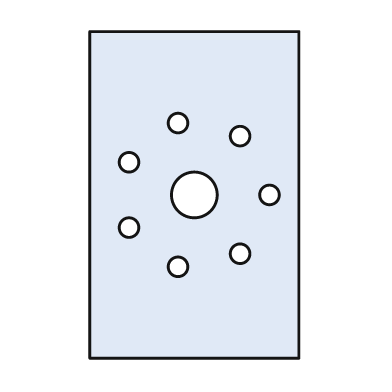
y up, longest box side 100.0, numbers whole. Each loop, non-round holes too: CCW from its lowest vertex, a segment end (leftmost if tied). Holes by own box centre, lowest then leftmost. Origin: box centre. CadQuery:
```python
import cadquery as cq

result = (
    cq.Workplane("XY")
    .moveTo(-32.0, -50.0)
    .lineTo(32.0, -50.0)
    .lineTo(32.0, 50.0)
    .lineTo(-32.0, 50.0)
    .close()
    .moveTo(-5.0, -22.0)
    .circle(3.0)
    .moveTo(14.0, -18.0)
    .circle(3.0)
    .moveTo(-20.0, -10.0)
    .circle(3.0)
    .moveTo(0.0, 0.0)
    .circle(7.0)
    .moveTo(23.0, 0.0)
    .circle(3.0)
    .moveTo(-20.0, 10.0)
    .circle(3.0)
    .moveTo(14.0, 18.0)
    .circle(3.0)
    .moveTo(-5.0, 22.0)
    .circle(3.0)
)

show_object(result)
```